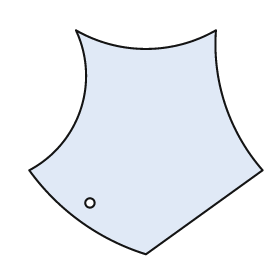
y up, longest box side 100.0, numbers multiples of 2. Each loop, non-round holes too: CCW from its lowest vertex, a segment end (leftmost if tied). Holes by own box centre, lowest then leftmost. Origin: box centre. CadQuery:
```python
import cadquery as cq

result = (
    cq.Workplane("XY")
    .moveTo(0.0, -48.0)
    .lineTo(50.0, -12.0)
    .threePointArc((34.0, 16.0), (30.0, 48.0))
    .threePointArc((0.0, 40.0), (-30.0, 48.0))
    .threePointArc((-28.0, 14.0), (-50.0, -12.0))
    .threePointArc((-28.0, -34.0), (0.0, -48.0))
    .close()
    .moveTo(-24.0, -26.0)
    .circle(2.0)
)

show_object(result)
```